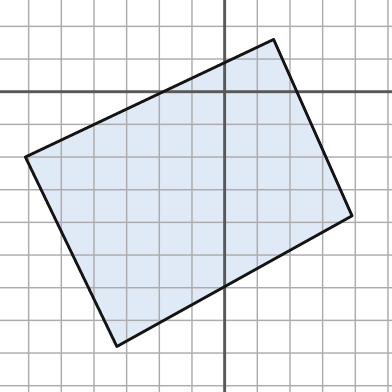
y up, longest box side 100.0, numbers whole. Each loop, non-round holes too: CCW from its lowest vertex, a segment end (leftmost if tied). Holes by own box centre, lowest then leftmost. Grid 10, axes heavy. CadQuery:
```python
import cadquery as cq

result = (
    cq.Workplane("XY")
    .moveTo(-33.0, -78.0)
    .lineTo(39.0, -38.0)
    .lineTo(15.0, 16.0)
    .lineTo(-61.0, -20.0)
    .close()
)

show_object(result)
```